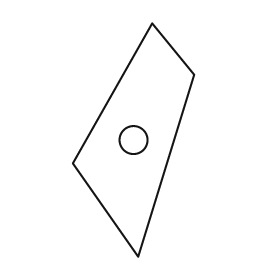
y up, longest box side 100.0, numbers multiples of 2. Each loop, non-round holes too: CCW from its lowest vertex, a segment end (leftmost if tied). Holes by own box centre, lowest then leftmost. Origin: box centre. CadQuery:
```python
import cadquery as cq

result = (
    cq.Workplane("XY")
    .moveTo(2.0, -50.0)
    .lineTo(26.0, 28.0)
    .lineTo(8.0, 50.0)
    .lineTo(-26.0, -10.0)
    .close()
    .moveTo(0.0, 0.0)
    .circle(6.0)
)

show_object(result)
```